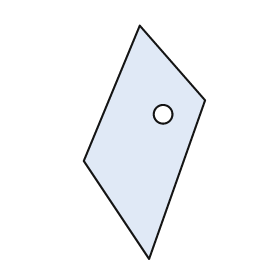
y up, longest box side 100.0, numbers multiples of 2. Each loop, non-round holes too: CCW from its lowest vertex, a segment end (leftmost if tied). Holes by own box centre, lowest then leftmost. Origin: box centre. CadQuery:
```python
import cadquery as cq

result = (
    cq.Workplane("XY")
    .moveTo(2.0, -50.0)
    .lineTo(26.0, 18.0)
    .lineTo(-2.0, 50.0)
    .lineTo(-26.0, -8.0)
    .close()
    .moveTo(8.0, 12.0)
    .circle(4.0)
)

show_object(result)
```